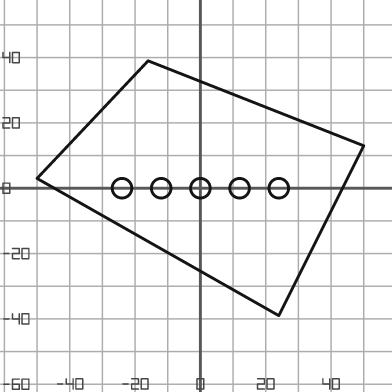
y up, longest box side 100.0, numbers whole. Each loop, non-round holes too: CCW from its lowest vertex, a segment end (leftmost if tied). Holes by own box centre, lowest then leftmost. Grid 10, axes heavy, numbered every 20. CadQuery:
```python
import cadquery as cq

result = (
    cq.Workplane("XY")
    .moveTo(24.0, -39.0)
    .lineTo(50.0, 13.0)
    .lineTo(-16.0, 39.0)
    .lineTo(-50.0, 3.0)
    .close()
    .moveTo(-24.0, 0.0)
    .circle(3.0)
    .moveTo(-12.0, 0.0)
    .circle(3.0)
    .moveTo(0.0, 0.0)
    .circle(3.0)
    .moveTo(12.0, 0.0)
    .circle(3.0)
    .moveTo(24.0, 0.0)
    .circle(3.0)
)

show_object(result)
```